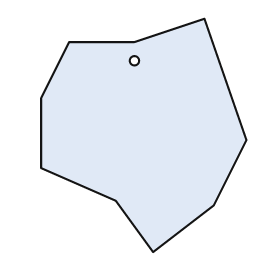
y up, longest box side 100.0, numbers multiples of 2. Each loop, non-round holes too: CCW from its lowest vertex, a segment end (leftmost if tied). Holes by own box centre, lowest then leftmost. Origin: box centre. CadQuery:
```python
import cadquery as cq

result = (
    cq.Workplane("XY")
    .moveTo(4.0, -50.0)
    .lineTo(30.0, -30.0)
    .lineTo(44.0, -2.0)
    .lineTo(26.0, 50.0)
    .lineTo(-4.0, 40.0)
    .lineTo(-32.0, 40.0)
    .lineTo(-44.0, 16.0)
    .lineTo(-44.0, -14.0)
    .lineTo(-12.0, -28.0)
    .close()
    .moveTo(-4.0, 32.0)
    .circle(2.0)
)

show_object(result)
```